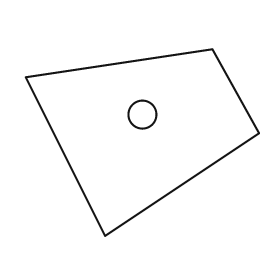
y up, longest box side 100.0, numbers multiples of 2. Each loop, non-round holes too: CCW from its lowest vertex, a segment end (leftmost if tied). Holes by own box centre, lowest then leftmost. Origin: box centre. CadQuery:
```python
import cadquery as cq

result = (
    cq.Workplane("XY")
    .moveTo(-16.0, -40.0)
    .lineTo(50.0, 4.0)
    .lineTo(30.0, 40.0)
    .lineTo(-50.0, 28.0)
    .close()
    .moveTo(0.0, 12.0)
    .circle(6.0)
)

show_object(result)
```